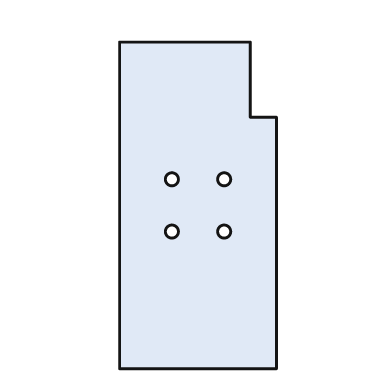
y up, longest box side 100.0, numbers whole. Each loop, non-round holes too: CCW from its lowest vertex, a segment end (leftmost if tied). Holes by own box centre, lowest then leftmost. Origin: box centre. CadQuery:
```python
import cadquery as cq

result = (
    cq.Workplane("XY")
    .moveTo(-24.0, -50.0)
    .lineTo(24.0, -50.0)
    .lineTo(24.0, 27.0)
    .lineTo(16.0, 27.0)
    .lineTo(16.0, 50.0)
    .lineTo(-24.0, 50.0)
    .close()
    .moveTo(-8.0, -8.0)
    .circle(2.0)
    .moveTo(8.0, -8.0)
    .circle(2.0)
    .moveTo(-8.0, 8.0)
    .circle(2.0)
    .moveTo(8.0, 8.0)
    .circle(2.0)
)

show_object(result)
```